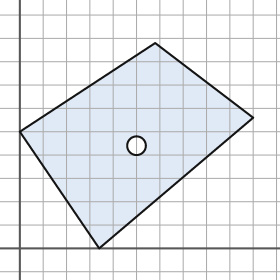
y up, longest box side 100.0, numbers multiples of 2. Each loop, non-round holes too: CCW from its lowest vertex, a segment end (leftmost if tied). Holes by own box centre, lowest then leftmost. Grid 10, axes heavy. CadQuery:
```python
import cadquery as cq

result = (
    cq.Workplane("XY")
    .moveTo(34.0, 0.0)
    .lineTo(100.0, 56.0)
    .lineTo(58.0, 88.0)
    .lineTo(0.0, 50.0)
    .close()
    .moveTo(50.0, 44.0)
    .circle(4.0)
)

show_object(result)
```